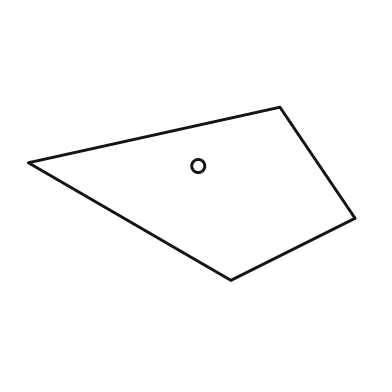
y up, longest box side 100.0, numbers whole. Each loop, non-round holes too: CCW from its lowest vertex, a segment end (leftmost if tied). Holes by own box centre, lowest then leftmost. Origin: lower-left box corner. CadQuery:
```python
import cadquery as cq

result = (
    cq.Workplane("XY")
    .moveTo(62.0, 0.0)
    .lineTo(100.0, 19.0)
    .lineTo(77.0, 53.0)
    .lineTo(0.0, 36.0)
    .close()
    .moveTo(52.0, 35.0)
    .circle(2.0)
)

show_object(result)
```